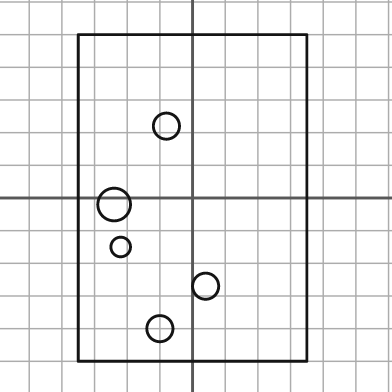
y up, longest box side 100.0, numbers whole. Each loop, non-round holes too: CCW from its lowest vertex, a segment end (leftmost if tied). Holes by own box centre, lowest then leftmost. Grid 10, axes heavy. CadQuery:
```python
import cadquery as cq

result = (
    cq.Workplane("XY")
    .moveTo(-35.0, -50.0)
    .lineTo(35.0, -50.0)
    .lineTo(35.0, 50.0)
    .lineTo(-35.0, 50.0)
    .close()
    .moveTo(-10.0, -40.0)
    .circle(4.0)
    .moveTo(4.0, -27.0)
    .circle(4.0)
    .moveTo(-22.0, -15.0)
    .circle(3.0)
    .moveTo(-24.0, -2.0)
    .circle(5.0)
    .moveTo(-8.0, 22.0)
    .circle(4.0)
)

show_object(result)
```